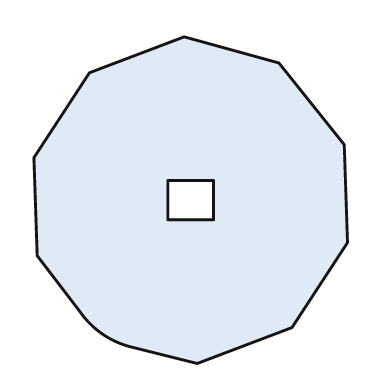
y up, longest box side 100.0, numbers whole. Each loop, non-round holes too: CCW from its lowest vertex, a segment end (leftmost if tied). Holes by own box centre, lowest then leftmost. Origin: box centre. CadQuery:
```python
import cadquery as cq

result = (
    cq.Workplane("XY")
    .moveTo(2.0, -50.0)
    .lineTo(31.0, -39.0)
    .lineTo(48.0, -13.0)
    .lineTo(47.0, 17.0)
    .lineTo(27.0, 42.0)
    .lineTo(-2.0, 50.0)
    .lineTo(-31.0, 39.0)
    .lineTo(-48.0, 13.0)
    .lineTo(-47.0, -17.0)
    .lineTo(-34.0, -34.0)
    .threePointArc((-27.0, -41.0), (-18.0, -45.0))
    .close()
    .moveTo(-7.0, -6.0)
    .lineTo(7.0, -6.0)
    .lineTo(7.0, 6.0)
    .lineTo(-7.0, 6.0)
    .close()
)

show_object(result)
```